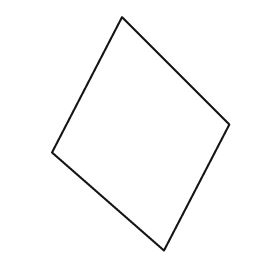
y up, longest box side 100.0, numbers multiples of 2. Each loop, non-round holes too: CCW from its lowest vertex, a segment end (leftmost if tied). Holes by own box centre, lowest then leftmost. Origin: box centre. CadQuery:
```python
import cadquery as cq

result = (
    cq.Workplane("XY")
    .moveTo(10.0, -50.0)
    .lineTo(38.0, 4.0)
    .lineTo(-8.0, 50.0)
    .lineTo(-38.0, -8.0)
    .close()
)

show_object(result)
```